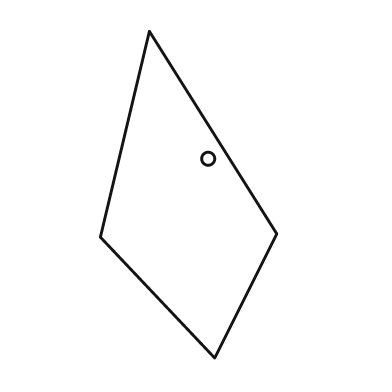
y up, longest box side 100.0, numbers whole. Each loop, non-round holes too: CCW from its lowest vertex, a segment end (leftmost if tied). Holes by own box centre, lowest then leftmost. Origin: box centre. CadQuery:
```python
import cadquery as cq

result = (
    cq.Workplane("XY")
    .moveTo(8.0, -50.0)
    .lineTo(27.0, -12.0)
    .lineTo(-12.0, 50.0)
    .lineTo(-27.0, -13.0)
    .close()
    .moveTo(6.0, 11.0)
    .circle(2.0)
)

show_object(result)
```